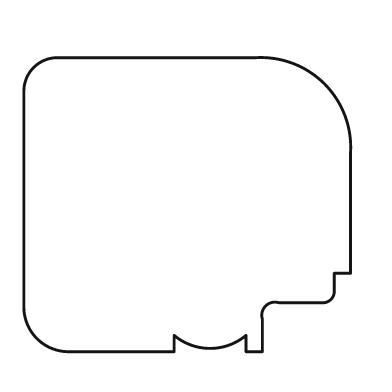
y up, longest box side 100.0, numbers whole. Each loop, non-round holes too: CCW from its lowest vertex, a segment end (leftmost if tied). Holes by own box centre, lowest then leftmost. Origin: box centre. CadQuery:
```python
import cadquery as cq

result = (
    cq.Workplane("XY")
    .moveTo(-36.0, -45.0)
    .lineTo(-4.0, -45.0)
    .lineTo(-4.0, -40.0)
    .threePointArc((7.0, -44.0), (18.0, -40.0))
    .lineTo(18.0, -45.0)
    .lineTo(23.0, -45.0)
    .lineTo(23.0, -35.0)
    .threePointArc((24.0, -31.0), (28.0, -30.0))
    .lineTo(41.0, -30.0)
    .threePointArc((44.0, -29.0), (45.0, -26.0))
    .lineTo(45.0, -21.0)
    .lineTo(50.0, -21.0)
    .lineTo(50.0, 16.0)
    .threePointArc((42.0, 37.0), (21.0, 45.0))
    .lineTo(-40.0, 45.0)
    .threePointArc((-47.0, 42.0), (-50.0, 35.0))
    .lineTo(-50.0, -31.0)
    .threePointArc((-46.0, -41.0), (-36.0, -45.0))
    .close()
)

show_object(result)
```